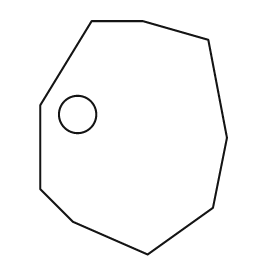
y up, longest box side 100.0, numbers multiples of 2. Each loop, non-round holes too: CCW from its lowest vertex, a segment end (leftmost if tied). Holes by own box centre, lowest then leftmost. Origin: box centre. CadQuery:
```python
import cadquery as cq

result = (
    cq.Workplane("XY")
    .moveTo(6.0, -50.0)
    .lineTo(34.0, -30.0)
    .lineTo(40.0, 0.0)
    .lineTo(32.0, 42.0)
    .lineTo(4.0, 50.0)
    .lineTo(-18.0, 50.0)
    .lineTo(-40.0, 14.0)
    .lineTo(-40.0, -22.0)
    .lineTo(-26.0, -36.0)
    .close()
    .moveTo(-24.0, 10.0)
    .circle(8.0)
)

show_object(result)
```